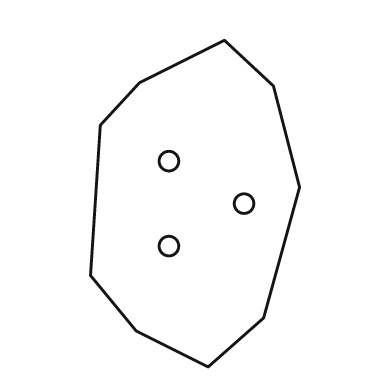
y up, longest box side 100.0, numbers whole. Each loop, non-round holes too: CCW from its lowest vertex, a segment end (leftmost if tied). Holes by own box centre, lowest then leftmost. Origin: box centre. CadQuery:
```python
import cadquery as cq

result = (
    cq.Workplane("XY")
    .moveTo(4.0, -50.0)
    .lineTo(21.0, -35.0)
    .lineTo(32.0, 5.0)
    .lineTo(24.0, 36.0)
    .lineTo(9.0, 50.0)
    .lineTo(-17.0, 37.0)
    .lineTo(-29.0, 24.0)
    .lineTo(-32.0, -22.0)
    .lineTo(-18.0, -39.0)
    .close()
    .moveTo(-8.0, -13.0)
    .circle(3.0)
    .moveTo(15.0, 0.0)
    .circle(3.0)
    .moveTo(-8.0, 13.0)
    .circle(3.0)
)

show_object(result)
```